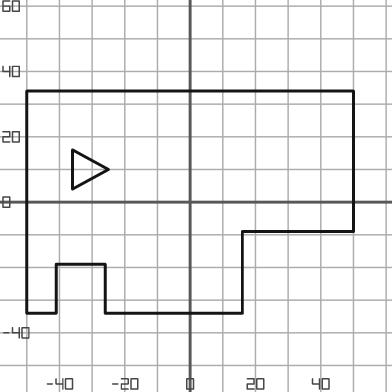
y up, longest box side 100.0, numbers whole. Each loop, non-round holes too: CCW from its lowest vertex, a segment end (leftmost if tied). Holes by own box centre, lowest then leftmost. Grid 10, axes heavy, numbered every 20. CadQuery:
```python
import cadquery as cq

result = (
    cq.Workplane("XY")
    .moveTo(-50.0, -34.0)
    .lineTo(-41.0, -34.0)
    .lineTo(-41.0, -19.0)
    .lineTo(-26.0, -19.0)
    .lineTo(-26.0, -34.0)
    .lineTo(16.0, -34.0)
    .lineTo(16.0, -9.0)
    .lineTo(50.0, -9.0)
    .lineTo(50.0, 34.0)
    .lineTo(-50.0, 34.0)
    .close()
    .moveTo(-36.0, 4.0)
    .lineTo(-25.0, 10.0)
    .lineTo(-36.0, 16.0)
    .close()
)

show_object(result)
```